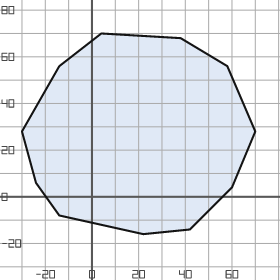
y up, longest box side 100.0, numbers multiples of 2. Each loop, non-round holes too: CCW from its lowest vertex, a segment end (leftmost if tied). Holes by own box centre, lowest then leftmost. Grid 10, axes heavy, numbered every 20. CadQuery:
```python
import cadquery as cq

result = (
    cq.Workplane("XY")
    .moveTo(22.0, -16.0)
    .lineTo(42.0, -14.0)
    .lineTo(60.0, 4.0)
    .lineTo(70.0, 28.0)
    .lineTo(58.0, 56.0)
    .lineTo(38.0, 68.0)
    .lineTo(4.0, 70.0)
    .lineTo(-14.0, 56.0)
    .lineTo(-30.0, 28.0)
    .lineTo(-24.0, 6.0)
    .lineTo(-14.0, -8.0)
    .close()
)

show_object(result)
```